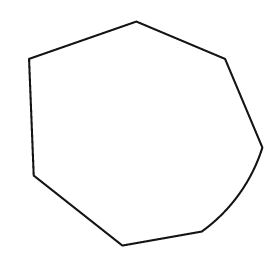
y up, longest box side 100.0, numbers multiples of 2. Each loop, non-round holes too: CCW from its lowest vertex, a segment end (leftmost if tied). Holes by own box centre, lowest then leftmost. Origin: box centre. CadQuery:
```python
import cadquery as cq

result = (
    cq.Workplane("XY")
    .moveTo(-10.0, -48.0)
    .lineTo(24.0, -42.0)
    .threePointArc((40.0, -26.0), (50.0, -6.0))
    .lineTo(34.0, 32.0)
    .lineTo(-4.0, 48.0)
    .lineTo(-50.0, 32.0)
    .lineTo(-48.0, -18.0)
    .close()
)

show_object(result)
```